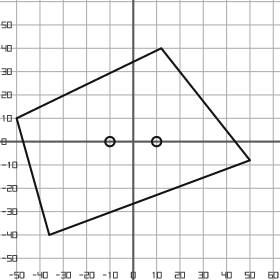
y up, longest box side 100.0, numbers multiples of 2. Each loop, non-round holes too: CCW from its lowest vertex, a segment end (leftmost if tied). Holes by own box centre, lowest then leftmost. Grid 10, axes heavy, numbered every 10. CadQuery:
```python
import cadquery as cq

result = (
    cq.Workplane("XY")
    .moveTo(-36.0, -40.0)
    .lineTo(50.0, -8.0)
    .lineTo(12.0, 40.0)
    .lineTo(-50.0, 10.0)
    .close()
    .moveTo(-10.0, 0.0)
    .circle(2.0)
    .moveTo(10.0, 0.0)
    .circle(2.0)
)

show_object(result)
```